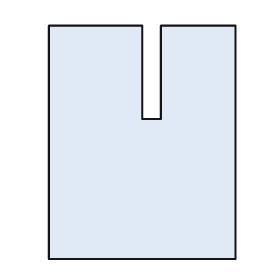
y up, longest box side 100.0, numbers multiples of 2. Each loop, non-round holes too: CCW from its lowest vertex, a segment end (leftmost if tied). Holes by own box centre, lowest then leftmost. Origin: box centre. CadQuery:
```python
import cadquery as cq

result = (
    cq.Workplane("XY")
    .moveTo(-40.0, -50.0)
    .lineTo(40.0, -50.0)
    .lineTo(40.0, 50.0)
    .lineTo(8.0, 50.0)
    .lineTo(8.0, 10.0)
    .lineTo(0.0, 10.0)
    .lineTo(0.0, 50.0)
    .lineTo(-40.0, 50.0)
    .close()
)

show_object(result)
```